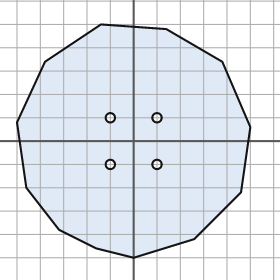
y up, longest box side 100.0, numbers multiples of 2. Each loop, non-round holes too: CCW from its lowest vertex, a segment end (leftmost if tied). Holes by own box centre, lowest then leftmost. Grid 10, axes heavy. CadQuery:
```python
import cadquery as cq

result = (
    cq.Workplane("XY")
    .moveTo(0.0, -50.0)
    .lineTo(26.0, -42.0)
    .lineTo(46.0, -22.0)
    .lineTo(50.0, 6.0)
    .lineTo(38.0, 34.0)
    .lineTo(14.0, 48.0)
    .lineTo(-14.0, 50.0)
    .lineTo(-38.0, 34.0)
    .lineTo(-50.0, 8.0)
    .lineTo(-46.0, -20.0)
    .lineTo(-32.0, -38.0)
    .lineTo(-16.0, -46.0)
    .close()
    .moveTo(-10.0, -10.0)
    .circle(2.0)
    .moveTo(10.0, -10.0)
    .circle(2.0)
    .moveTo(-10.0, 10.0)
    .circle(2.0)
    .moveTo(10.0, 10.0)
    .circle(2.0)
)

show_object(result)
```